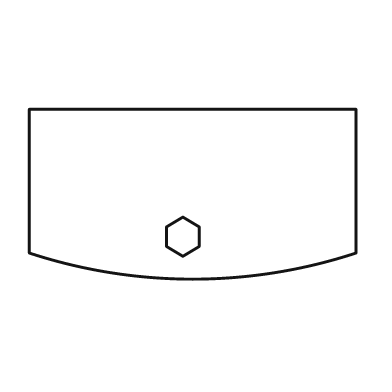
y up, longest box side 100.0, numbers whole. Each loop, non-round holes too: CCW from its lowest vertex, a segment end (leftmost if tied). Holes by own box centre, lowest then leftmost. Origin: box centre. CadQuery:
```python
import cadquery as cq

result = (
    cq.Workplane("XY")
    .moveTo(-50.0, -18.0)
    .threePointArc((0.0, -26.0), (50.0, -18.0))
    .lineTo(50.0, 26.0)
    .lineTo(-50.0, 26.0)
    .close()
    .moveTo(-3.0, -19.0)
    .lineTo(2.0, -16.0)
    .lineTo(2.0, -10.0)
    .lineTo(-3.0, -7.0)
    .lineTo(-8.0, -10.0)
    .lineTo(-8.0, -16.0)
    .close()
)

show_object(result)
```